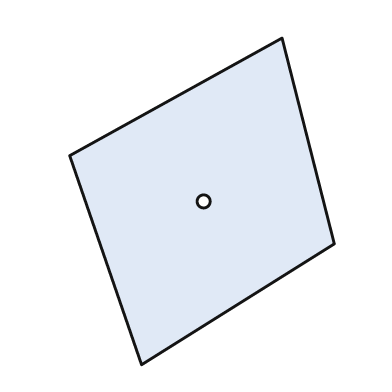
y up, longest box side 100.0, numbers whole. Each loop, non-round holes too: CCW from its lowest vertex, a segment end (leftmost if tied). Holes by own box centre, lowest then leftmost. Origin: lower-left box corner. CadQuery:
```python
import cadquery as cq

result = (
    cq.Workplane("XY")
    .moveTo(22.0, 0.0)
    .lineTo(81.0, 37.0)
    .lineTo(65.0, 100.0)
    .lineTo(0.0, 64.0)
    .close()
    .moveTo(41.0, 50.0)
    .circle(2.0)
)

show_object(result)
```